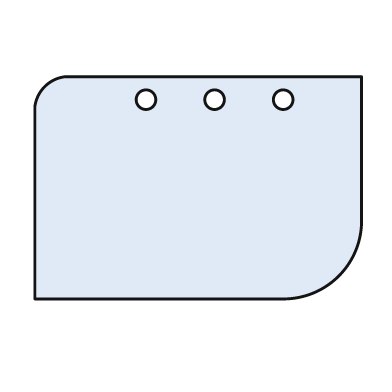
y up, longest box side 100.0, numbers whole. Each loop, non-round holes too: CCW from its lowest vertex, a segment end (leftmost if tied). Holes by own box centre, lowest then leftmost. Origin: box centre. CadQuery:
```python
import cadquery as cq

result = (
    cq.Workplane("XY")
    .moveTo(-50.0, -34.0)
    .lineTo(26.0, -34.0)
    .threePointArc((43.0, -27.0), (50.0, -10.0))
    .lineTo(50.0, 34.0)
    .lineTo(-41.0, 34.0)
    .threePointArc((-47.0, 31.0), (-50.0, 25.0))
    .close()
    .moveTo(-16.0, 27.0)
    .circle(3.0)
    .moveTo(5.0, 27.0)
    .circle(3.0)
    .moveTo(26.0, 27.0)
    .circle(3.0)
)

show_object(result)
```